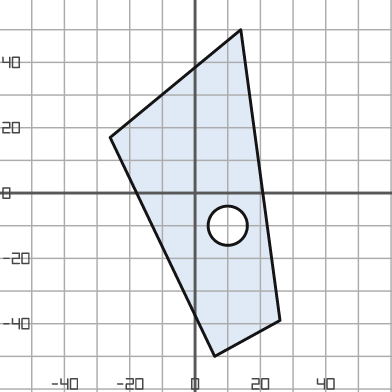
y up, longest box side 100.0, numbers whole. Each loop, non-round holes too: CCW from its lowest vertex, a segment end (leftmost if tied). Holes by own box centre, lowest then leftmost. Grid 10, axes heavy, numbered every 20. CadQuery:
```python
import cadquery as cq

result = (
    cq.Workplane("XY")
    .moveTo(6.0, -50.0)
    .lineTo(26.0, -39.0)
    .lineTo(14.0, 50.0)
    .lineTo(-26.0, 17.0)
    .close()
    .moveTo(10.0, -10.0)
    .circle(6.0)
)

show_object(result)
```